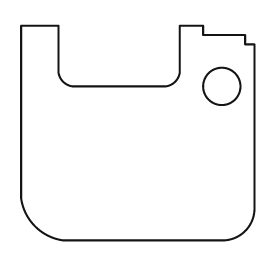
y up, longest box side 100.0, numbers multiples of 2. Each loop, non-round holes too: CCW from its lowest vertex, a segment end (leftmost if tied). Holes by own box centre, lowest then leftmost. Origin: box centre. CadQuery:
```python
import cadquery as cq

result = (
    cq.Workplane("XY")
    .moveTo(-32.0, -46.0)
    .lineTo(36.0, -46.0)
    .threePointArc((46.0, -42.0), (50.0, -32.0))
    .lineTo(50.0, 38.0)
    .lineTo(46.0, 38.0)
    .lineTo(46.0, 42.0)
    .lineTo(28.0, 42.0)
    .lineTo(28.0, 46.0)
    .lineTo(18.0, 46.0)
    .lineTo(18.0, 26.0)
    .threePointArc((16.0, 22.0), (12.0, 20.0))
    .lineTo(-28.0, 20.0)
    .threePointArc((-32.0, 22.0), (-34.0, 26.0))
    .lineTo(-34.0, 46.0)
    .lineTo(-50.0, 46.0)
    .lineTo(-50.0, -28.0)
    .threePointArc((-44.0, -40.0), (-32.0, -46.0))
    .close()
    .moveTo(36.0, 20.0)
    .circle(8.0)
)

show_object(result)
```